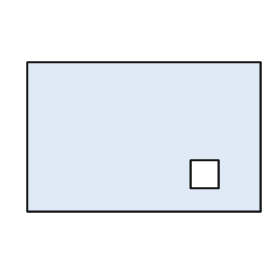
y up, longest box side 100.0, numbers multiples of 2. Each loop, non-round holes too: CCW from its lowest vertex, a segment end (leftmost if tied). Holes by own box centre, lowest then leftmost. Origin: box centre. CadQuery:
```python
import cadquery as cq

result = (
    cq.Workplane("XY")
    .moveTo(-50.0, -32.0)
    .lineTo(50.0, -32.0)
    .lineTo(50.0, 32.0)
    .lineTo(-50.0, 32.0)
    .close()
    .moveTo(20.0, -22.0)
    .lineTo(32.0, -22.0)
    .lineTo(32.0, -10.0)
    .lineTo(20.0, -10.0)
    .close()
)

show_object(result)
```